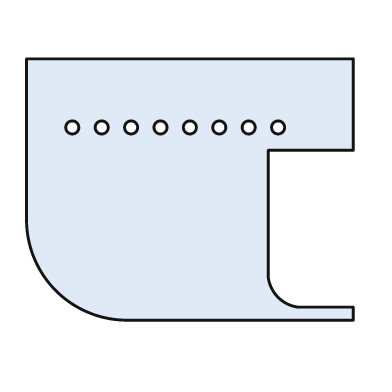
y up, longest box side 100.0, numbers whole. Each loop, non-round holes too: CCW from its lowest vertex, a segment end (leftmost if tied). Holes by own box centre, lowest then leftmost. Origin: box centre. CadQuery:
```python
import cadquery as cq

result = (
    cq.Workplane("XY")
    .moveTo(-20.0, -40.0)
    .lineTo(50.0, -40.0)
    .lineTo(50.0, -36.0)
    .lineTo(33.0, -36.0)
    .threePointArc((27.0, -33.0), (24.0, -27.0))
    .lineTo(24.0, 12.0)
    .lineTo(50.0, 12.0)
    .lineTo(50.0, 40.0)
    .lineTo(-50.0, 40.0)
    .lineTo(-50.0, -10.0)
    .threePointArc((-41.0, -31.0), (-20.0, -40.0))
    .close()
    .moveTo(-36.0, 19.0)
    .circle(2.0)
    .moveTo(-27.0, 19.0)
    .circle(2.0)
    .moveTo(-18.0, 19.0)
    .circle(2.0)
    .moveTo(-9.0, 19.0)
    .circle(2.0)
    .moveTo(0.0, 19.0)
    .circle(2.0)
    .moveTo(9.0, 19.0)
    .circle(2.0)
    .moveTo(18.0, 19.0)
    .circle(2.0)
    .moveTo(27.0, 19.0)
    .circle(2.0)
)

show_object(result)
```